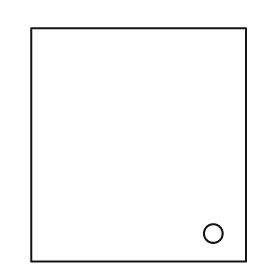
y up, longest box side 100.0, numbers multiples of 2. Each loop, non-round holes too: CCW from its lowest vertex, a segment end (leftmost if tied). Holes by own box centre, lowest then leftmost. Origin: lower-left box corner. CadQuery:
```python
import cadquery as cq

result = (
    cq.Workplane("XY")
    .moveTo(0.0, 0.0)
    .lineTo(92.0, 0.0)
    .lineTo(92.0, 100.0)
    .lineTo(0.0, 100.0)
    .close()
    .moveTo(78.0, 12.0)
    .circle(4.0)
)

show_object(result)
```